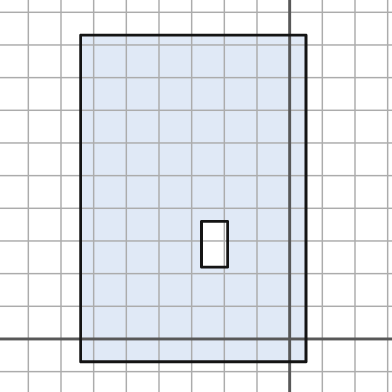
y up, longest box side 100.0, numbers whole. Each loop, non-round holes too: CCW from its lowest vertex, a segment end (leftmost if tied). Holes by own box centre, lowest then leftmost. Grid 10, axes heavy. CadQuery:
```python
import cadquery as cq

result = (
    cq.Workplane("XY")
    .moveTo(-64.0, -7.0)
    .lineTo(5.0, -7.0)
    .lineTo(5.0, 93.0)
    .lineTo(-64.0, 93.0)
    .close()
    .moveTo(-27.0, 22.0)
    .lineTo(-19.0, 22.0)
    .lineTo(-19.0, 36.0)
    .lineTo(-27.0, 36.0)
    .close()
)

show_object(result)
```